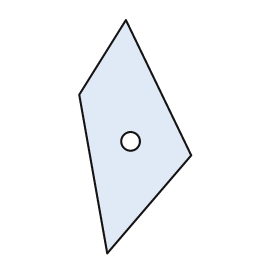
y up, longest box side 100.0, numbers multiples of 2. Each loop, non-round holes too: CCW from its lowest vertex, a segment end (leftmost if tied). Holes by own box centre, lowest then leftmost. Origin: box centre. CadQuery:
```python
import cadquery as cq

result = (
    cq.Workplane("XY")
    .moveTo(-12.0, -50.0)
    .lineTo(24.0, -8.0)
    .lineTo(-4.0, 50.0)
    .lineTo(-24.0, 18.0)
    .close()
    .moveTo(-2.0, -2.0)
    .circle(4.0)
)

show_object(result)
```